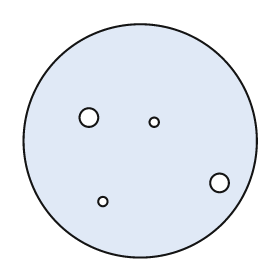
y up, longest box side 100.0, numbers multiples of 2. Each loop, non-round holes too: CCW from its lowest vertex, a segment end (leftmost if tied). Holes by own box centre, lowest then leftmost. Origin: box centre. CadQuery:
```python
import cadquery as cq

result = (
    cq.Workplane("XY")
    .moveTo(0.0, 0.0)
    .circle(50.0)
    .moveTo(-16.0, -26.0)
    .circle(2.0)
    .moveTo(34.0, -18.0)
    .circle(4.0)
    .moveTo(6.0, 8.0)
    .circle(2.0)
    .moveTo(-22.0, 10.0)
    .circle(4.0)
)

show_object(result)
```